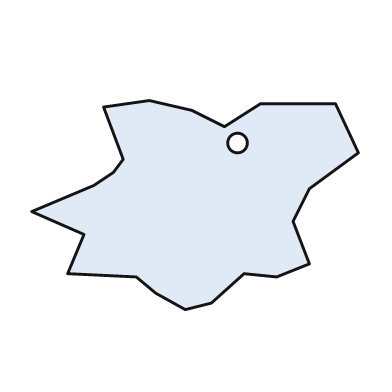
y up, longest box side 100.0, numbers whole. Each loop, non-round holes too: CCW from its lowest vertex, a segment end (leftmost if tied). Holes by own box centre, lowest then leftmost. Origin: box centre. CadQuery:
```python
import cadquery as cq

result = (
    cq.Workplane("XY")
    .moveTo(-3.0, -32.0)
    .lineTo(5.0, -30.0)
    .lineTo(15.0, -21.0)
    .lineTo(25.0, -22.0)
    .lineTo(35.0, -18.0)
    .lineTo(30.0, -5.0)
    .lineTo(35.0, 5.0)
    .lineTo(50.0, 16.0)
    .lineTo(43.0, 31.0)
    .lineTo(20.0, 31.0)
    .lineTo(9.0, 24.0)
    .lineTo(-1.0, 29.0)
    .lineTo(-14.0, 32.0)
    .lineTo(-28.0, 30.0)
    .lineTo(-22.0, 14.0)
    .lineTo(-25.0, 10.0)
    .lineTo(-31.0, 6.0)
    .lineTo(-50.0, -2.0)
    .lineTo(-34.0, -9.0)
    .lineTo(-39.0, -21.0)
    .lineTo(-18.0, -22.0)
    .lineTo(-12.0, -27.0)
    .close()
    .moveTo(13.0, 19.0)
    .circle(3.0)
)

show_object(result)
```